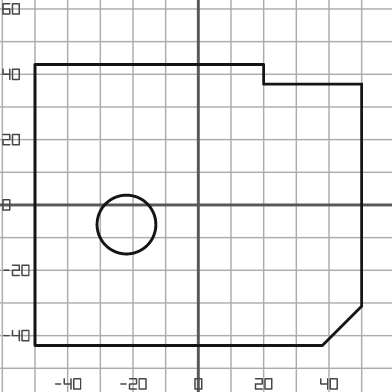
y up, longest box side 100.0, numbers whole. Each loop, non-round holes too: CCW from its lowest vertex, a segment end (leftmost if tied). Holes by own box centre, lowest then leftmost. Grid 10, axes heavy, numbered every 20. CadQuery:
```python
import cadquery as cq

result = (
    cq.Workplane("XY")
    .moveTo(-50.0, -43.0)
    .lineTo(38.0, -43.0)
    .lineTo(50.0, -31.0)
    .lineTo(50.0, 37.0)
    .lineTo(20.0, 37.0)
    .lineTo(20.0, 43.0)
    .lineTo(-50.0, 43.0)
    .close()
    .moveTo(-22.0, -6.0)
    .circle(9.0)
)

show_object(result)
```